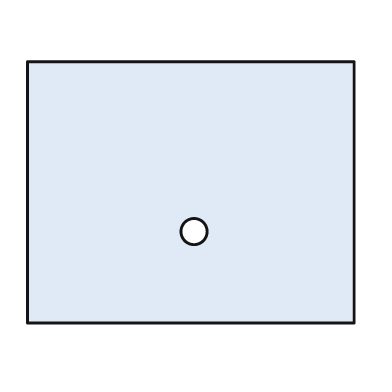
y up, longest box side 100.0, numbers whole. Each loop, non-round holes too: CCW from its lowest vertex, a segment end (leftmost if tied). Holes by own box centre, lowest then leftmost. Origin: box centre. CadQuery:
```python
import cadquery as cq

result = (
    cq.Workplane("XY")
    .moveTo(-50.0, -40.0)
    .lineTo(50.0, -40.0)
    .lineTo(50.0, 40.0)
    .lineTo(-50.0, 40.0)
    .close()
    .moveTo(1.0, -12.0)
    .circle(4.0)
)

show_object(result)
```